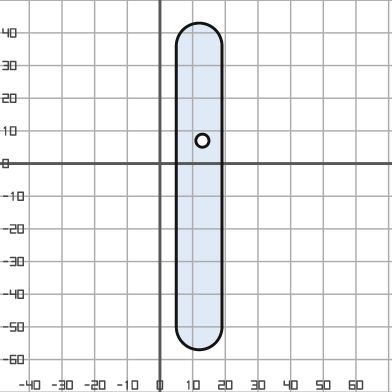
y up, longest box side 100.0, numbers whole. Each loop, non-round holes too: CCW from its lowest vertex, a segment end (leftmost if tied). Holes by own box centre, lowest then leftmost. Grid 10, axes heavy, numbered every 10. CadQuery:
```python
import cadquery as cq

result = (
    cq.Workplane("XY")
    .moveTo(5.0, -50.0)
    .threePointArc((12.0, -57.0), (19.0, -50.0))
    .lineTo(19.0, 36.0)
    .threePointArc((12.0, 43.0), (5.0, 36.0))
    .close()
    .moveTo(13.0, 7.0)
    .circle(2.0)
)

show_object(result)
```